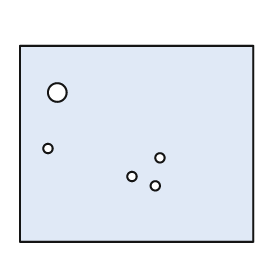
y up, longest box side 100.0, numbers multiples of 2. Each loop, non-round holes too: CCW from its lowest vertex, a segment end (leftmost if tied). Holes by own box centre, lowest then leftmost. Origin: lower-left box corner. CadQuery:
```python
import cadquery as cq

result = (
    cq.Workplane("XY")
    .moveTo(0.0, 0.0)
    .lineTo(100.0, 0.0)
    .lineTo(100.0, 84.0)
    .lineTo(0.0, 84.0)
    .close()
    .moveTo(58.0, 24.0)
    .circle(2.0)
    .moveTo(48.0, 28.0)
    .circle(2.0)
    .moveTo(60.0, 36.0)
    .circle(2.0)
    .moveTo(12.0, 40.0)
    .circle(2.0)
    .moveTo(16.0, 64.0)
    .circle(4.0)
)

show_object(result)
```